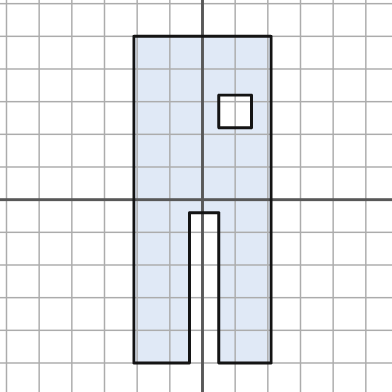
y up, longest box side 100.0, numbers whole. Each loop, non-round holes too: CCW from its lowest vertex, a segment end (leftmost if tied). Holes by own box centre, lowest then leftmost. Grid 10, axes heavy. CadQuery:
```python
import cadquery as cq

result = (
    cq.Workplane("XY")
    .moveTo(-21.0, -50.0)
    .lineTo(-4.0, -50.0)
    .lineTo(-4.0, -4.0)
    .lineTo(5.0, -4.0)
    .lineTo(5.0, -50.0)
    .lineTo(21.0, -50.0)
    .lineTo(21.0, 50.0)
    .lineTo(-21.0, 50.0)
    .close()
    .moveTo(5.0, 22.0)
    .lineTo(15.0, 22.0)
    .lineTo(15.0, 32.0)
    .lineTo(5.0, 32.0)
    .close()
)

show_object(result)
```